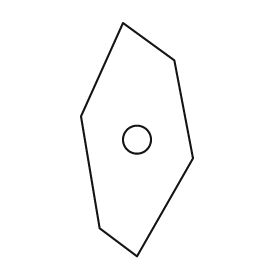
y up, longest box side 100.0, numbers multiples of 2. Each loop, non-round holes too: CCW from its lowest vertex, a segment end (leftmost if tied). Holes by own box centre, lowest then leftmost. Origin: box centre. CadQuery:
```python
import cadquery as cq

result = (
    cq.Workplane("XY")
    .moveTo(0.0, -50.0)
    .lineTo(24.0, -8.0)
    .lineTo(16.0, 34.0)
    .lineTo(-6.0, 50.0)
    .lineTo(-24.0, 10.0)
    .lineTo(-16.0, -38.0)
    .close()
    .moveTo(0.0, 0.0)
    .circle(6.0)
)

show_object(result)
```